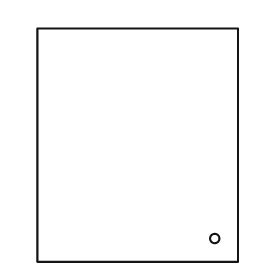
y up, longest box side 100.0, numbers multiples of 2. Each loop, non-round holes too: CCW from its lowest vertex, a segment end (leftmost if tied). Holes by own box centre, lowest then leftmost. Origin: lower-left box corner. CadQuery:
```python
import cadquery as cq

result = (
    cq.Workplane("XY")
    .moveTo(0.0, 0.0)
    .lineTo(86.0, 0.0)
    .lineTo(86.0, 100.0)
    .lineTo(0.0, 100.0)
    .close()
    .moveTo(76.0, 10.0)
    .circle(2.0)
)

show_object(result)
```